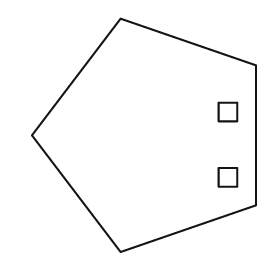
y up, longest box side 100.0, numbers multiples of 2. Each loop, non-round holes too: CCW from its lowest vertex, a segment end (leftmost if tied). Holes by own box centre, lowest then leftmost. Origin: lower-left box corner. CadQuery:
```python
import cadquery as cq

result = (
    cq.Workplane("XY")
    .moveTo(38.0, 0.0)
    .lineTo(96.0, 20.0)
    .lineTo(96.0, 80.0)
    .lineTo(38.0, 100.0)
    .lineTo(0.0, 50.0)
    .close()
    .moveTo(80.0, 28.0)
    .lineTo(88.0, 28.0)
    .lineTo(88.0, 36.0)
    .lineTo(80.0, 36.0)
    .close()
    .moveTo(80.0, 56.0)
    .lineTo(88.0, 56.0)
    .lineTo(88.0, 64.0)
    .lineTo(80.0, 64.0)
    .close()
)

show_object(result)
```